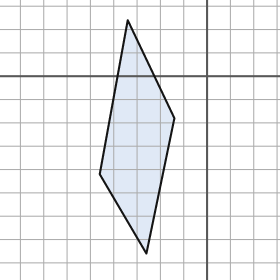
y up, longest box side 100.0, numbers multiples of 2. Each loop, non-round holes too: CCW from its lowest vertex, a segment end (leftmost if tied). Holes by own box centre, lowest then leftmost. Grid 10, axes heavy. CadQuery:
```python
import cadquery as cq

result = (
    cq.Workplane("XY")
    .moveTo(-26.0, -76.0)
    .lineTo(-14.0, -18.0)
    .lineTo(-34.0, 24.0)
    .lineTo(-46.0, -42.0)
    .close()
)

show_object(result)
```